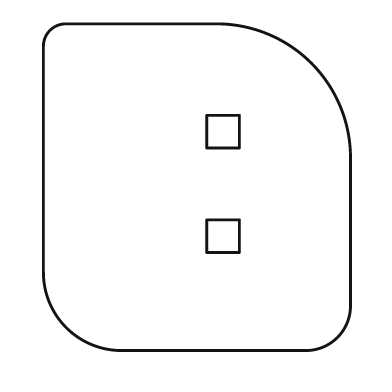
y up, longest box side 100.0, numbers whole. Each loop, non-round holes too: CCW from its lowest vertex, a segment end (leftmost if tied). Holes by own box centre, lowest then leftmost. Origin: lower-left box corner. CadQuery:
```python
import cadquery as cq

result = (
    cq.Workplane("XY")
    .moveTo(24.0, 0.0)
    .lineTo(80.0, 0.0)
    .threePointArc((90.0, 4.0), (94.0, 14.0))
    .lineTo(94.0, 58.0)
    .threePointArc((82.0, 88.0), (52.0, 100.0))
    .lineTo(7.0, 100.0)
    .threePointArc((2.0, 98.0), (0.0, 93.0))
    .lineTo(0.0, 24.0)
    .threePointArc((7.0, 7.0), (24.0, 0.0))
    .close()
    .moveTo(50.0, 30.0)
    .lineTo(60.0, 30.0)
    .lineTo(60.0, 40.0)
    .lineTo(50.0, 40.0)
    .close()
    .moveTo(50.0, 62.0)
    .lineTo(60.0, 62.0)
    .lineTo(60.0, 72.0)
    .lineTo(50.0, 72.0)
    .close()
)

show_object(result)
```